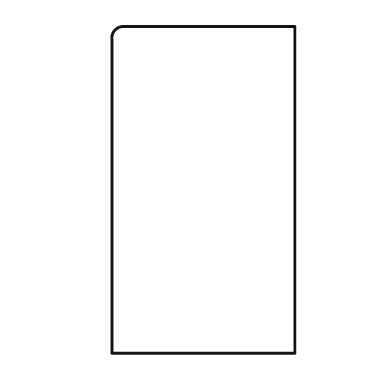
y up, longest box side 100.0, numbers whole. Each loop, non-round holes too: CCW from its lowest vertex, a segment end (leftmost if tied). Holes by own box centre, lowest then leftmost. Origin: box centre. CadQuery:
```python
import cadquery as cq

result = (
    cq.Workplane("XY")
    .moveTo(-28.0, -50.0)
    .lineTo(28.0, -50.0)
    .lineTo(28.0, 50.0)
    .lineTo(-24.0, 50.0)
    .threePointArc((-27.0, 49.0), (-28.0, 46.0))
    .close()
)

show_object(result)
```